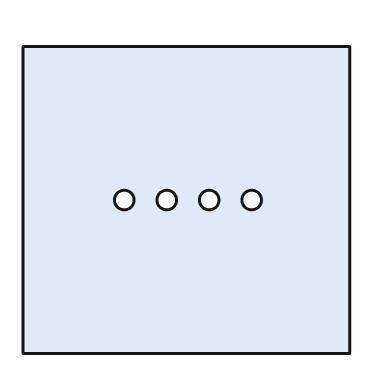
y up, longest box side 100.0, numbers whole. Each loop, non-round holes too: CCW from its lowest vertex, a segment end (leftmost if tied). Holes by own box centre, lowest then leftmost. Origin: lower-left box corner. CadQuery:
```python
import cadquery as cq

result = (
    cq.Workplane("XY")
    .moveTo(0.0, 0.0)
    .lineTo(100.0, 0.0)
    .lineTo(100.0, 94.0)
    .lineTo(0.0, 94.0)
    .close()
    .moveTo(31.0, 47.0)
    .circle(3.0)
    .moveTo(44.0, 47.0)
    .circle(3.0)
    .moveTo(57.0, 47.0)
    .circle(3.0)
    .moveTo(70.0, 47.0)
    .circle(3.0)
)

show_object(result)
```